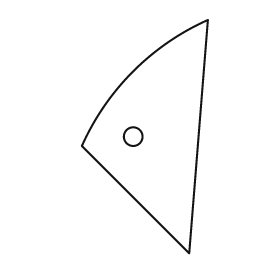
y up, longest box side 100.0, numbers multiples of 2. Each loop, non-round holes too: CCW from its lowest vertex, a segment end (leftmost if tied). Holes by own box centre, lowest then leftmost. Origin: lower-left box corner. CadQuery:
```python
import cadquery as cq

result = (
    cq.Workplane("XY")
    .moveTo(46.0, 0.0)
    .lineTo(54.0, 100.0)
    .threePointArc((22.0, 78.0), (0.0, 46.0))
    .close()
    .moveTo(22.0, 50.0)
    .circle(4.0)
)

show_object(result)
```